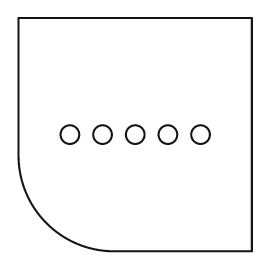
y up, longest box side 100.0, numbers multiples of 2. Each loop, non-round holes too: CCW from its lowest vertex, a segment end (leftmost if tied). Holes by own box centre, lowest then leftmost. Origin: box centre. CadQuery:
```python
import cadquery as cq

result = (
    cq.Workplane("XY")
    .moveTo(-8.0, -50.0)
    .lineTo(50.0, -50.0)
    .lineTo(50.0, 50.0)
    .lineTo(-50.0, 50.0)
    .lineTo(-50.0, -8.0)
    .threePointArc((-38.0, -38.0), (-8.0, -50.0))
    .close()
    .moveTo(-28.0, 0.0)
    .circle(4.0)
    .moveTo(-14.0, 0.0)
    .circle(4.0)
    .moveTo(0.0, 0.0)
    .circle(4.0)
    .moveTo(14.0, 0.0)
    .circle(4.0)
    .moveTo(28.0, 0.0)
    .circle(4.0)
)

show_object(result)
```